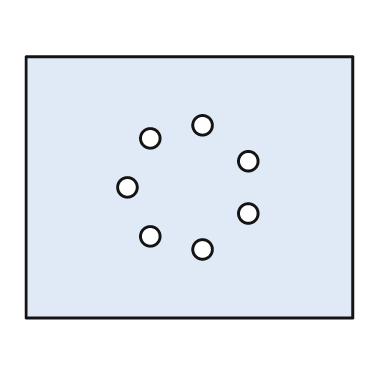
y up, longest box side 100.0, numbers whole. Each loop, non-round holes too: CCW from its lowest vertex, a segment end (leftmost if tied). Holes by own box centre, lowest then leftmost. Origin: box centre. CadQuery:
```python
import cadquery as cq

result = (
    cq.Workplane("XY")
    .moveTo(-50.0, -40.0)
    .lineTo(50.0, -40.0)
    .lineTo(50.0, 40.0)
    .lineTo(-50.0, 40.0)
    .close()
    .moveTo(4.0, -19.0)
    .circle(3.0)
    .moveTo(-12.0, -15.0)
    .circle(3.0)
    .moveTo(18.0, -8.0)
    .circle(3.0)
    .moveTo(-19.0, 0.0)
    .circle(3.0)
    .moveTo(18.0, 8.0)
    .circle(3.0)
    .moveTo(-12.0, 15.0)
    .circle(3.0)
    .moveTo(4.0, 19.0)
    .circle(3.0)
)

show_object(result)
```